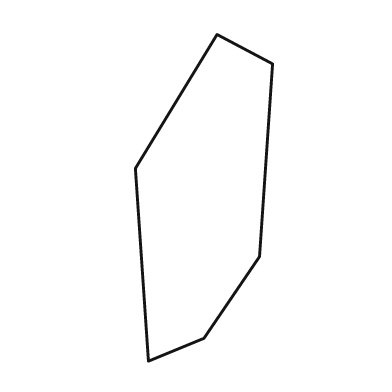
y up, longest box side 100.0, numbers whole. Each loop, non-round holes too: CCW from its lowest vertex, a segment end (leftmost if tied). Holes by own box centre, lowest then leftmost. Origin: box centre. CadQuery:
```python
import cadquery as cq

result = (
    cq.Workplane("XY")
    .moveTo(-17.0, -50.0)
    .lineTo(0.0, -43.0)
    .lineTo(17.0, -18.0)
    .lineTo(21.0, 41.0)
    .lineTo(4.0, 50.0)
    .lineTo(-21.0, 9.0)
    .close()
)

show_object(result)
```